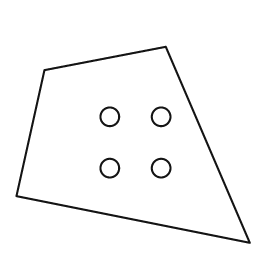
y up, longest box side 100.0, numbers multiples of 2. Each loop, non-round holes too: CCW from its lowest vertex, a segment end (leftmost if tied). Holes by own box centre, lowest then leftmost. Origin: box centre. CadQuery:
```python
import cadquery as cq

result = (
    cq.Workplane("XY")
    .moveTo(50.0, -42.0)
    .lineTo(14.0, 42.0)
    .lineTo(-38.0, 32.0)
    .lineTo(-50.0, -22.0)
    .close()
    .moveTo(-10.0, -10.0)
    .circle(4.0)
    .moveTo(12.0, -10.0)
    .circle(4.0)
    .moveTo(-10.0, 12.0)
    .circle(4.0)
    .moveTo(12.0, 12.0)
    .circle(4.0)
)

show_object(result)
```